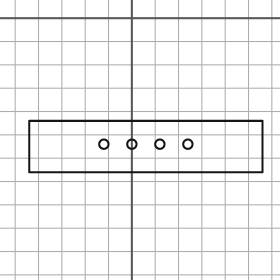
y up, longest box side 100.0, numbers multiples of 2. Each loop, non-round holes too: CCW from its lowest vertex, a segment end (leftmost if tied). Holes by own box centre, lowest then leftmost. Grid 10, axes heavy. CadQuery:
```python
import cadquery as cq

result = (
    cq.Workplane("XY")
    .moveTo(-44.0, -66.0)
    .lineTo(56.0, -66.0)
    .lineTo(56.0, -44.0)
    .lineTo(-44.0, -44.0)
    .close()
    .moveTo(-12.0, -54.0)
    .circle(2.0)
    .moveTo(0.0, -54.0)
    .circle(2.0)
    .moveTo(12.0, -54.0)
    .circle(2.0)
    .moveTo(24.0, -54.0)
    .circle(2.0)
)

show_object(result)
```